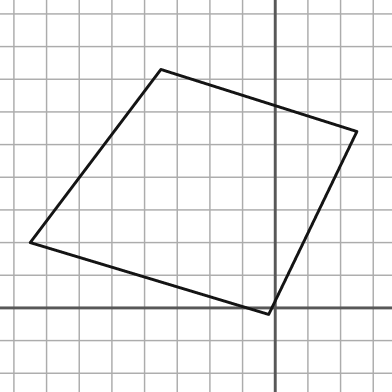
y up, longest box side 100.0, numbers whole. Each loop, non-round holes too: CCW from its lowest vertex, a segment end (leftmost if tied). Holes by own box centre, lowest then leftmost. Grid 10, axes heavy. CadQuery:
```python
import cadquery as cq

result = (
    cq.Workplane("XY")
    .moveTo(-2.0, -2.0)
    .lineTo(25.0, 54.0)
    .lineTo(-35.0, 73.0)
    .lineTo(-75.0, 20.0)
    .close()
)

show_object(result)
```